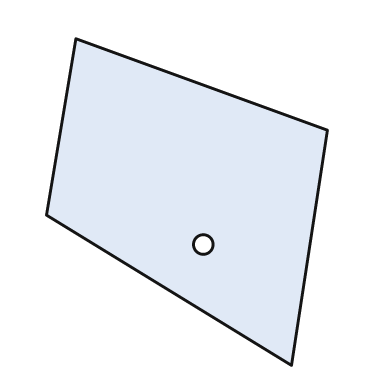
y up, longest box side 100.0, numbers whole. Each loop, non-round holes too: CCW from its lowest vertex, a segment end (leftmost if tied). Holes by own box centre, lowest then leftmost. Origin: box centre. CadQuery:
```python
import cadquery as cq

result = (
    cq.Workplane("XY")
    .moveTo(32.0, -50.0)
    .lineTo(43.0, 22.0)
    .lineTo(-34.0, 50.0)
    .lineTo(-43.0, -4.0)
    .close()
    .moveTo(5.0, -13.0)
    .circle(3.0)
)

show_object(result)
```